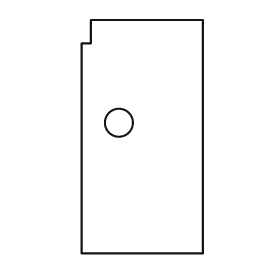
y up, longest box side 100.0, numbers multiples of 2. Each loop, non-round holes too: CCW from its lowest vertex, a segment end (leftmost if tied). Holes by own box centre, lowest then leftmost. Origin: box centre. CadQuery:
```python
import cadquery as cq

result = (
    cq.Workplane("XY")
    .moveTo(-26.0, -50.0)
    .lineTo(26.0, -50.0)
    .lineTo(26.0, 50.0)
    .lineTo(-22.0, 50.0)
    .lineTo(-22.0, 40.0)
    .lineTo(-26.0, 40.0)
    .close()
    .moveTo(-10.0, 6.0)
    .circle(6.0)
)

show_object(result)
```